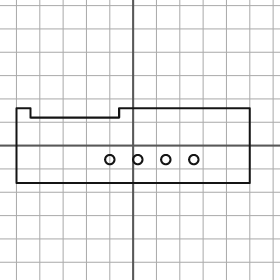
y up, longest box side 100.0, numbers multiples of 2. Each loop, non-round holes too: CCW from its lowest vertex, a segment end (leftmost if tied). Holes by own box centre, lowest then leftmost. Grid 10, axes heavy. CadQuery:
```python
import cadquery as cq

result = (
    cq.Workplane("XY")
    .moveTo(-50.0, -16.0)
    .lineTo(50.0, -16.0)
    .lineTo(50.0, 16.0)
    .lineTo(-6.0, 16.0)
    .lineTo(-6.0, 12.0)
    .lineTo(-44.0, 12.0)
    .lineTo(-44.0, 16.0)
    .lineTo(-50.0, 16.0)
    .close()
    .moveTo(-10.0, -6.0)
    .circle(2.0)
    .moveTo(2.0, -6.0)
    .circle(2.0)
    .moveTo(14.0, -6.0)
    .circle(2.0)
    .moveTo(26.0, -6.0)
    .circle(2.0)
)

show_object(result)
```